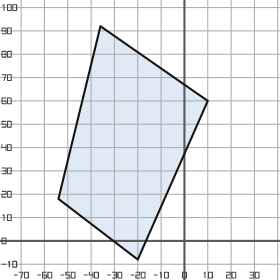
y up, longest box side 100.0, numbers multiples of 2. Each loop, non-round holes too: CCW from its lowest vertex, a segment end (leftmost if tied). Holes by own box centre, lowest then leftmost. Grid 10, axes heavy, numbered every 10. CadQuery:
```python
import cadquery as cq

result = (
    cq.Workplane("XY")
    .moveTo(-20.0, -8.0)
    .lineTo(10.0, 60.0)
    .lineTo(-36.0, 92.0)
    .lineTo(-54.0, 18.0)
    .close()
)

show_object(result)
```